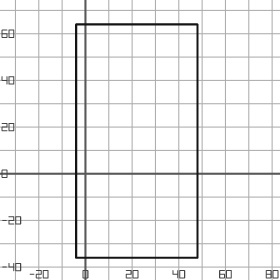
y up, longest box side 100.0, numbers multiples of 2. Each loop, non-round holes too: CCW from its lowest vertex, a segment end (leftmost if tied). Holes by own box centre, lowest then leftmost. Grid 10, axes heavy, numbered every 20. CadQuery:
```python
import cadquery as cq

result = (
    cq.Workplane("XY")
    .moveTo(-4.0, -36.0)
    .lineTo(48.0, -36.0)
    .lineTo(48.0, 64.0)
    .lineTo(-4.0, 64.0)
    .close()
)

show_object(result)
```